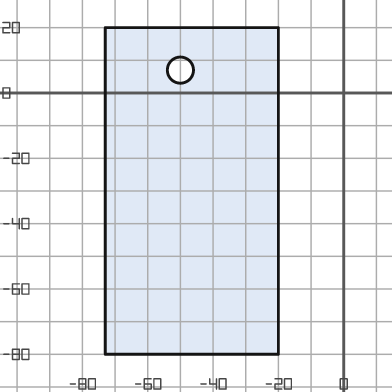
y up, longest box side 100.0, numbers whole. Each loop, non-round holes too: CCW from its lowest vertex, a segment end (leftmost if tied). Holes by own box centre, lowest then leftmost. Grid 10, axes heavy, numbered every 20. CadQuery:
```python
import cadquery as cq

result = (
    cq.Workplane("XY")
    .moveTo(-73.0, -80.0)
    .lineTo(-20.0, -80.0)
    .lineTo(-20.0, 20.0)
    .lineTo(-73.0, 20.0)
    .close()
    .moveTo(-50.0, 7.0)
    .circle(4.0)
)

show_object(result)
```